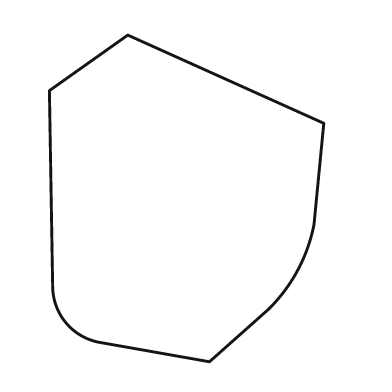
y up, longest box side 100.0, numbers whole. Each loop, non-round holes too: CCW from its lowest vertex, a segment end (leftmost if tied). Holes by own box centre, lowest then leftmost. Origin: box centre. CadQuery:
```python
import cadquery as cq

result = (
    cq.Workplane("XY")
    .moveTo(7.0, -50.0)
    .lineTo(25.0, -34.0)
    .threePointArc((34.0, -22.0), (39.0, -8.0))
    .lineTo(42.0, 23.0)
    .lineTo(-18.0, 50.0)
    .lineTo(-42.0, 33.0)
    .lineTo(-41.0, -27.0)
    .threePointArc((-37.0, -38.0), (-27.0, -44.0))
    .close()
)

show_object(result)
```